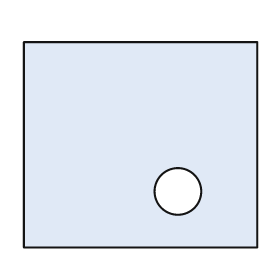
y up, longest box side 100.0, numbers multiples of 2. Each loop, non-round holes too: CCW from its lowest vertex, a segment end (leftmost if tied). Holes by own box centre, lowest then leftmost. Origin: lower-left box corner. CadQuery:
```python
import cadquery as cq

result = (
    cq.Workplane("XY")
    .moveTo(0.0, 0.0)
    .lineTo(100.0, 0.0)
    .lineTo(100.0, 88.0)
    .lineTo(0.0, 88.0)
    .close()
    .moveTo(66.0, 24.0)
    .circle(10.0)
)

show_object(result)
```